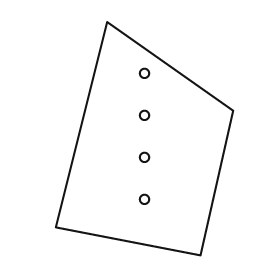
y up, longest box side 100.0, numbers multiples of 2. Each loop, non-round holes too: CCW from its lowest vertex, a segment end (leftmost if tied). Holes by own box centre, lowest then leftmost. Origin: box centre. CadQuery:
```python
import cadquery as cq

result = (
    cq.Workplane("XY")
    .moveTo(24.0, -50.0)
    .lineTo(38.0, 12.0)
    .lineTo(-16.0, 50.0)
    .lineTo(-38.0, -38.0)
    .close()
    .moveTo(0.0, -26.0)
    .circle(2.0)
    .moveTo(0.0, -8.0)
    .circle(2.0)
    .moveTo(0.0, 10.0)
    .circle(2.0)
    .moveTo(0.0, 28.0)
    .circle(2.0)
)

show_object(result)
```